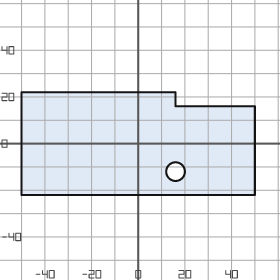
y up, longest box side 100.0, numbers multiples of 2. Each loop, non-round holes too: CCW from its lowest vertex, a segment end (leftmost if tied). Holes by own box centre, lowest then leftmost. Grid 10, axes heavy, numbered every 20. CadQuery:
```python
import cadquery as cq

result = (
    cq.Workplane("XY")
    .moveTo(-50.0, -22.0)
    .lineTo(50.0, -22.0)
    .lineTo(50.0, 16.0)
    .lineTo(16.0, 16.0)
    .lineTo(16.0, 22.0)
    .lineTo(-50.0, 22.0)
    .close()
    .moveTo(16.0, -12.0)
    .circle(4.0)
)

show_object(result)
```